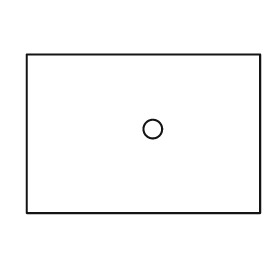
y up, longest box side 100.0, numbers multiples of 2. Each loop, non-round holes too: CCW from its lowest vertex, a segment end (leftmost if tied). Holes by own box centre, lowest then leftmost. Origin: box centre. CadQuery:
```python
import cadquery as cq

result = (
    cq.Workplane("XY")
    .moveTo(-50.0, -34.0)
    .lineTo(50.0, -34.0)
    .lineTo(50.0, 34.0)
    .lineTo(-50.0, 34.0)
    .close()
    .moveTo(4.0, 2.0)
    .circle(4.0)
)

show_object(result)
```